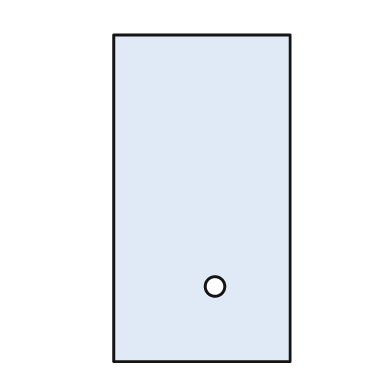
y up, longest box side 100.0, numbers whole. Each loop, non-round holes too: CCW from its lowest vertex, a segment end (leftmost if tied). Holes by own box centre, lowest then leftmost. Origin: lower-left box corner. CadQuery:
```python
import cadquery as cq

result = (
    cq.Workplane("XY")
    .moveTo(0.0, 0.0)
    .lineTo(54.0, 0.0)
    .lineTo(54.0, 100.0)
    .lineTo(0.0, 100.0)
    .close()
    .moveTo(31.0, 23.0)
    .circle(3.0)
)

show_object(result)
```